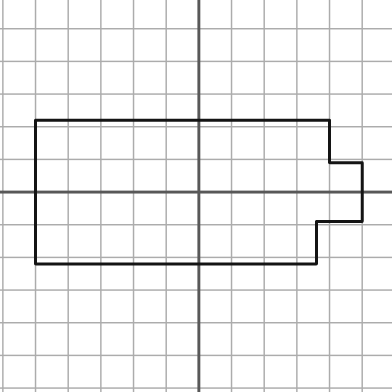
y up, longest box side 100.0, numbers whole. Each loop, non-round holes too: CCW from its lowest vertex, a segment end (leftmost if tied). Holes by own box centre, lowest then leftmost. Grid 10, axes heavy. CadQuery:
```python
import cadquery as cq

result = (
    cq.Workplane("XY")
    .moveTo(-50.0, -22.0)
    .lineTo(36.0, -22.0)
    .lineTo(36.0, -9.0)
    .lineTo(50.0, -9.0)
    .lineTo(50.0, 9.0)
    .lineTo(40.0, 9.0)
    .lineTo(40.0, 22.0)
    .lineTo(-50.0, 22.0)
    .close()
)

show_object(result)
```